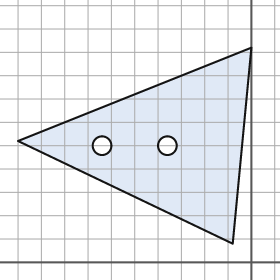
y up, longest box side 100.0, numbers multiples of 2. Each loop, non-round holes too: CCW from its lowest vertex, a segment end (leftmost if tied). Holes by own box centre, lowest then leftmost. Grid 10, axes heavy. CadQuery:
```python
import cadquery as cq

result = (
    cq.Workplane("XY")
    .moveTo(-8.0, 8.0)
    .lineTo(0.0, 92.0)
    .lineTo(-100.0, 52.0)
    .close()
    .moveTo(-64.0, 50.0)
    .circle(4.0)
    .moveTo(-36.0, 50.0)
    .circle(4.0)
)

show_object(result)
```